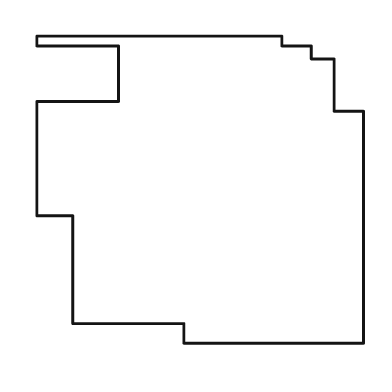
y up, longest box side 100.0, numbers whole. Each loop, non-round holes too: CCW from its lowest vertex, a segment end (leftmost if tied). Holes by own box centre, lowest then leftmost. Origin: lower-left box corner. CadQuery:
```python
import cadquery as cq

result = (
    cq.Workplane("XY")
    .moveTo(45.0, 0.0)
    .lineTo(100.0, 0.0)
    .lineTo(100.0, 71.0)
    .lineTo(91.0, 71.0)
    .lineTo(91.0, 87.0)
    .lineTo(84.0, 87.0)
    .lineTo(84.0, 91.0)
    .lineTo(75.0, 91.0)
    .lineTo(75.0, 94.0)
    .lineTo(0.0, 94.0)
    .lineTo(0.0, 91.0)
    .lineTo(25.0, 91.0)
    .lineTo(25.0, 74.0)
    .lineTo(0.0, 74.0)
    .lineTo(0.0, 39.0)
    .lineTo(11.0, 39.0)
    .lineTo(11.0, 6.0)
    .lineTo(45.0, 6.0)
    .close()
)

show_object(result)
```